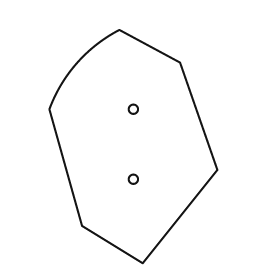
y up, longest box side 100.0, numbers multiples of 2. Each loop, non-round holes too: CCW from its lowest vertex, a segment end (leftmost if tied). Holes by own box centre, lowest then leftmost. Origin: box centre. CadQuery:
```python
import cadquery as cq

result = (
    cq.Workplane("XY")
    .moveTo(4.0, -50.0)
    .lineTo(36.0, -10.0)
    .lineTo(20.0, 36.0)
    .lineTo(-6.0, 50.0)
    .threePointArc((-24.0, 36.0), (-36.0, 16.0))
    .lineTo(-22.0, -34.0)
    .close()
    .moveTo(0.0, -14.0)
    .circle(2.0)
    .moveTo(0.0, 16.0)
    .circle(2.0)
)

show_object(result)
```